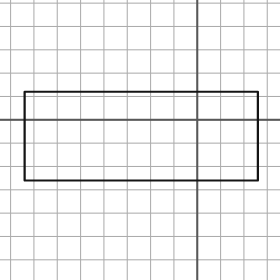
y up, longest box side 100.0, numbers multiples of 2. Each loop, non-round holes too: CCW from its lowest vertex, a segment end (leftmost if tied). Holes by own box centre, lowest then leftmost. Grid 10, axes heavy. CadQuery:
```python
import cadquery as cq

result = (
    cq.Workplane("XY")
    .moveTo(-74.0, -26.0)
    .lineTo(26.0, -26.0)
    .lineTo(26.0, 12.0)
    .lineTo(-74.0, 12.0)
    .close()
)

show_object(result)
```